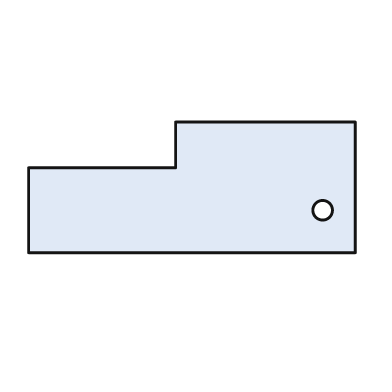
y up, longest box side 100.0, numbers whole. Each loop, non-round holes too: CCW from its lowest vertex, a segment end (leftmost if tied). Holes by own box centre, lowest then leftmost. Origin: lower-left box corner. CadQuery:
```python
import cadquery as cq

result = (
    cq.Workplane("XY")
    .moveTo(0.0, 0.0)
    .lineTo(100.0, 0.0)
    .lineTo(100.0, 40.0)
    .lineTo(45.0, 40.0)
    .lineTo(45.0, 26.0)
    .lineTo(0.0, 26.0)
    .close()
    .moveTo(90.0, 13.0)
    .circle(3.0)
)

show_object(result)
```